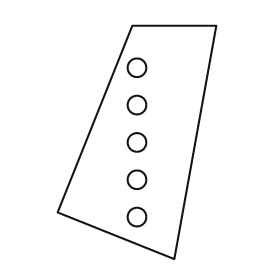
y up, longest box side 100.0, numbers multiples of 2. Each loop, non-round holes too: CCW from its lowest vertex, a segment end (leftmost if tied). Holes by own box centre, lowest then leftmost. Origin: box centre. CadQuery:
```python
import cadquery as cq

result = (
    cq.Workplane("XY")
    .moveTo(16.0, -50.0)
    .lineTo(34.0, 50.0)
    .lineTo(-2.0, 50.0)
    .lineTo(-34.0, -30.0)
    .close()
    .moveTo(0.0, -32.0)
    .circle(4.0)
    .moveTo(0.0, -16.0)
    .circle(4.0)
    .moveTo(0.0, 0.0)
    .circle(4.0)
    .moveTo(0.0, 16.0)
    .circle(4.0)
    .moveTo(0.0, 32.0)
    .circle(4.0)
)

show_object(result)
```